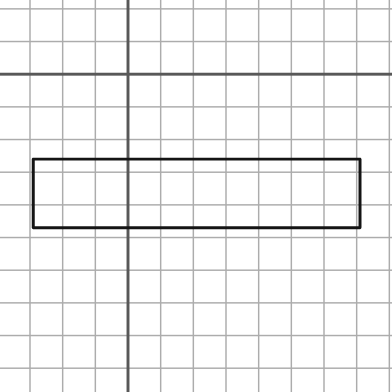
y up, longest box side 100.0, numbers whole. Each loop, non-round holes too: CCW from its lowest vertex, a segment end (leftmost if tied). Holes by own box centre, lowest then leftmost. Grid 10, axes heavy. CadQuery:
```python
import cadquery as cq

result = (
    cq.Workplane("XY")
    .moveTo(-29.0, -47.0)
    .lineTo(71.0, -47.0)
    .lineTo(71.0, -26.0)
    .lineTo(-29.0, -26.0)
    .close()
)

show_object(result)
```